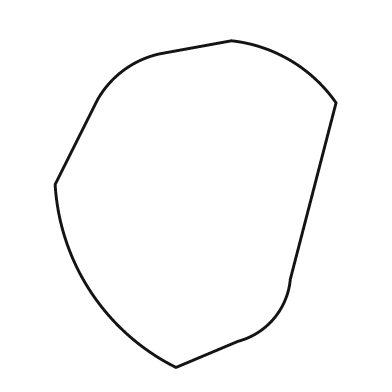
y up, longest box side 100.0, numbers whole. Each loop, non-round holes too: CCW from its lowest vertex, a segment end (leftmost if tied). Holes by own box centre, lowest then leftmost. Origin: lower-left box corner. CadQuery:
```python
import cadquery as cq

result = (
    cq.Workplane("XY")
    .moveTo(37.0, 0.0)
    .lineTo(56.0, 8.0)
    .threePointArc((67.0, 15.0), (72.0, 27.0))
    .lineTo(86.0, 81.0)
    .threePointArc((72.0, 94.0), (54.0, 100.0))
    .lineTo(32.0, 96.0)
    .threePointArc((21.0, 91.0), (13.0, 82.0))
    .lineTo(0.0, 56.0)
    .threePointArc((11.0, 23.0), (37.0, 0.0))
    .close()
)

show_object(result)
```